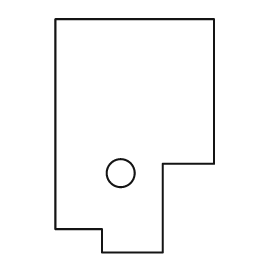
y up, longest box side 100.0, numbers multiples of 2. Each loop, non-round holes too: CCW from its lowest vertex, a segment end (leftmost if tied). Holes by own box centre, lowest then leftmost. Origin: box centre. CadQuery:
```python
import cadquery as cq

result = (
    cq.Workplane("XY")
    .moveTo(-14.0, -50.0)
    .lineTo(12.0, -50.0)
    .lineTo(12.0, -12.0)
    .lineTo(34.0, -12.0)
    .lineTo(34.0, 50.0)
    .lineTo(-34.0, 50.0)
    .lineTo(-34.0, -40.0)
    .lineTo(-14.0, -40.0)
    .close()
    .moveTo(-6.0, -16.0)
    .circle(6.0)
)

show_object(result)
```